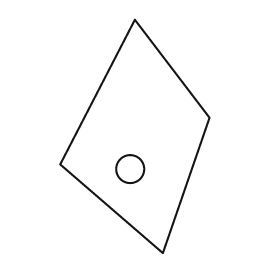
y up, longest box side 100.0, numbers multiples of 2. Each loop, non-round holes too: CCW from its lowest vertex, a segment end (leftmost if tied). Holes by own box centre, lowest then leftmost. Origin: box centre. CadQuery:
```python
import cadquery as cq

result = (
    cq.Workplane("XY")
    .moveTo(12.0, -50.0)
    .lineTo(32.0, 8.0)
    .lineTo(0.0, 50.0)
    .lineTo(-32.0, -12.0)
    .close()
    .moveTo(-2.0, -14.0)
    .circle(6.0)
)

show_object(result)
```